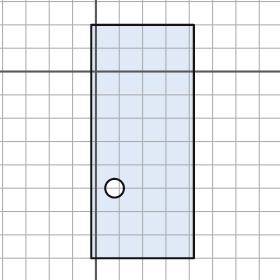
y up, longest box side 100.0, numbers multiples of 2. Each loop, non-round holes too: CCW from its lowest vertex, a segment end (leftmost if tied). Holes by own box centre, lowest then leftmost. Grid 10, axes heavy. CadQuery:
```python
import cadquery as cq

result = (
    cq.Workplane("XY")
    .moveTo(-2.0, -80.0)
    .lineTo(42.0, -80.0)
    .lineTo(42.0, 20.0)
    .lineTo(-2.0, 20.0)
    .close()
    .moveTo(8.0, -50.0)
    .circle(4.0)
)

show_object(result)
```